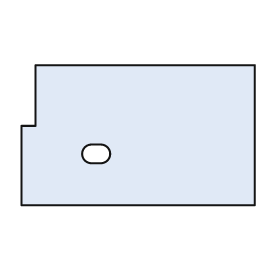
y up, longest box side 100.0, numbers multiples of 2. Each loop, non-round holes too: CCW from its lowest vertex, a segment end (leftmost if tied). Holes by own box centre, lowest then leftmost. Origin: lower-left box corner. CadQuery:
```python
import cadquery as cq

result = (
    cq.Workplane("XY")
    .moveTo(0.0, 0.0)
    .lineTo(100.0, 0.0)
    .lineTo(100.0, 60.0)
    .lineTo(6.0, 60.0)
    .lineTo(6.0, 34.0)
    .lineTo(0.0, 34.0)
    .close()
    .moveTo(30.0, 18.0)
    .lineTo(34.0, 18.0)
    .threePointArc((38.0, 22.0), (34.0, 26.0))
    .lineTo(30.0, 26.0)
    .threePointArc((26.0, 22.0), (30.0, 18.0))
    .close()
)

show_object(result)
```